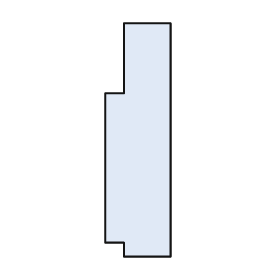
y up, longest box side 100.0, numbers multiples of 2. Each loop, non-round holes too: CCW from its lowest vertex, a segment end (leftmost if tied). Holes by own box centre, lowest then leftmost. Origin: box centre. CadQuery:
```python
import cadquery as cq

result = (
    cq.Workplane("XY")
    .moveTo(-6.0, -50.0)
    .lineTo(14.0, -50.0)
    .lineTo(14.0, 50.0)
    .lineTo(-6.0, 50.0)
    .lineTo(-6.0, 20.0)
    .lineTo(-14.0, 20.0)
    .lineTo(-14.0, -44.0)
    .lineTo(-6.0, -44.0)
    .close()
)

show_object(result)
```